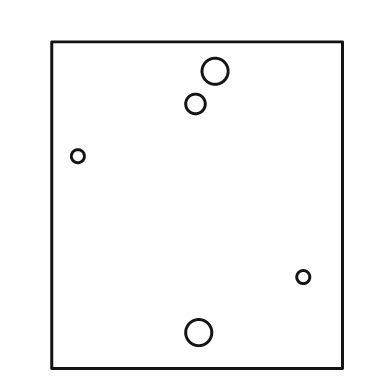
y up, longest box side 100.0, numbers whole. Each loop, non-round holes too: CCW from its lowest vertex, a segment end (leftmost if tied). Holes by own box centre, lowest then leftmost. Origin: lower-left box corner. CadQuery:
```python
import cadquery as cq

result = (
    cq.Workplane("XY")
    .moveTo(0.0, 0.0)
    .lineTo(89.0, 0.0)
    .lineTo(89.0, 100.0)
    .lineTo(0.0, 100.0)
    .close()
    .moveTo(45.0, 11.0)
    .circle(4.0)
    .moveTo(77.0, 28.0)
    .circle(2.0)
    .moveTo(8.0, 65.0)
    .circle(2.0)
    .moveTo(44.0, 81.0)
    .circle(3.0)
    .moveTo(50.0, 91.0)
    .circle(4.0)
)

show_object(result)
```